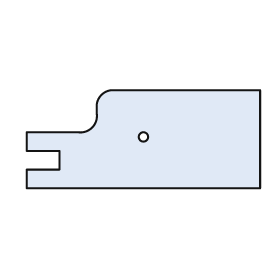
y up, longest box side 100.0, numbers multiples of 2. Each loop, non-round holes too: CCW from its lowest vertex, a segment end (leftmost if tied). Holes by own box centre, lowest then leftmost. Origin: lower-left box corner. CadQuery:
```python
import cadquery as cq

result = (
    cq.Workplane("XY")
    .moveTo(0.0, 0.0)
    .lineTo(100.0, 0.0)
    .lineTo(100.0, 42.0)
    .lineTo(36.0, 42.0)
    .threePointArc((32.0, 40.0), (30.0, 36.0))
    .lineTo(30.0, 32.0)
    .threePointArc((28.0, 26.0), (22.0, 24.0))
    .lineTo(0.0, 24.0)
    .lineTo(0.0, 16.0)
    .lineTo(14.0, 16.0)
    .lineTo(14.0, 8.0)
    .lineTo(0.0, 8.0)
    .close()
    .moveTo(50.0, 22.0)
    .circle(2.0)
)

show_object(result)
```